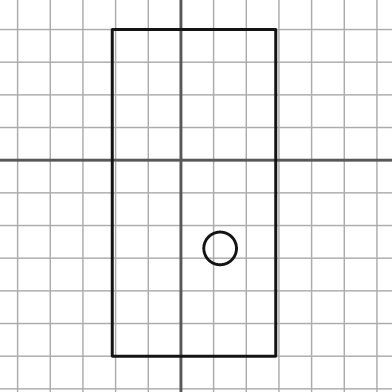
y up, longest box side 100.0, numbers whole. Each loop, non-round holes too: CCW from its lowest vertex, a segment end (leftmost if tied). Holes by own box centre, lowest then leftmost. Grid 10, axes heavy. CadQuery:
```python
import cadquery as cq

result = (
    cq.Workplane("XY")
    .moveTo(-21.0, -60.0)
    .lineTo(29.0, -60.0)
    .lineTo(29.0, 40.0)
    .lineTo(-21.0, 40.0)
    .close()
    .moveTo(12.0, -27.0)
    .circle(5.0)
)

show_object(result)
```